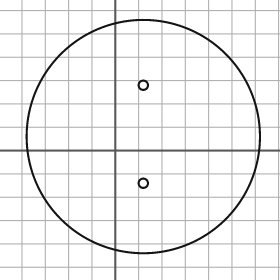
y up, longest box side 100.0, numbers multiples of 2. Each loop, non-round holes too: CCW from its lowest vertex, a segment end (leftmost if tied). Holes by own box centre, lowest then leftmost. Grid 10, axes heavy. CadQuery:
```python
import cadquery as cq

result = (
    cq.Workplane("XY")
    .moveTo(12.0, 6.0)
    .circle(50.0)
    .moveTo(12.0, -14.0)
    .circle(2.0)
    .moveTo(12.0, 28.0)
    .circle(2.0)
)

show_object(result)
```